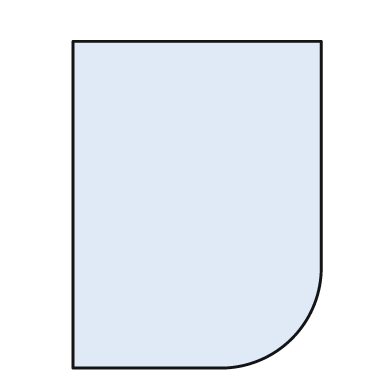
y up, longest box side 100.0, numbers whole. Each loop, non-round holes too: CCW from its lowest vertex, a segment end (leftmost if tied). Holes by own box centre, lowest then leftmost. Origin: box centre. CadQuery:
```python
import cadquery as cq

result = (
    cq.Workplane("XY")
    .moveTo(-38.0, -50.0)
    .lineTo(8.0, -50.0)
    .threePointArc((29.0, -41.0), (38.0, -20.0))
    .lineTo(38.0, 50.0)
    .lineTo(-38.0, 50.0)
    .close()
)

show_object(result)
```